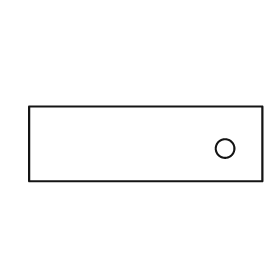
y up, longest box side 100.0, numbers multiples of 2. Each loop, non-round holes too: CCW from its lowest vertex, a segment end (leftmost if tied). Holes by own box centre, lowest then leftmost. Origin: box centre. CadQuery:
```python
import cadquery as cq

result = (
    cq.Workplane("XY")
    .moveTo(-50.0, -16.0)
    .lineTo(50.0, -16.0)
    .lineTo(50.0, 16.0)
    .lineTo(-50.0, 16.0)
    .close()
    .moveTo(34.0, -2.0)
    .circle(4.0)
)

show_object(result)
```